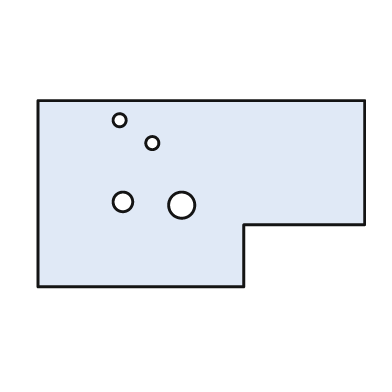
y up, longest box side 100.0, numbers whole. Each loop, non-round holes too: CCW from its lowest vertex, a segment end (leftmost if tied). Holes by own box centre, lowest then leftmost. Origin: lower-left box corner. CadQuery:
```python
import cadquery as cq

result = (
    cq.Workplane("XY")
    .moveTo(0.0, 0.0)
    .lineTo(63.0, 0.0)
    .lineTo(63.0, 19.0)
    .lineTo(100.0, 19.0)
    .lineTo(100.0, 57.0)
    .lineTo(0.0, 57.0)
    .close()
    .moveTo(44.0, 25.0)
    .circle(4.0)
    .moveTo(26.0, 26.0)
    .circle(3.0)
    .moveTo(35.0, 44.0)
    .circle(2.0)
    .moveTo(25.0, 51.0)
    .circle(2.0)
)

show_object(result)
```